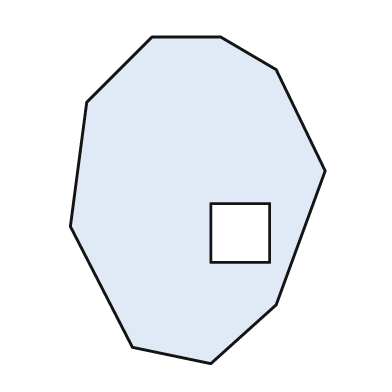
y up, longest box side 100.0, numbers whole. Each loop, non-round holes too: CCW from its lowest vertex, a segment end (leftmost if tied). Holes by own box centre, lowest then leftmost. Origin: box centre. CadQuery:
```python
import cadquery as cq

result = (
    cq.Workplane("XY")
    .moveTo(4.0, -50.0)
    .lineTo(24.0, -32.0)
    .lineTo(39.0, 9.0)
    .lineTo(24.0, 40.0)
    .lineTo(7.0, 50.0)
    .lineTo(-14.0, 50.0)
    .lineTo(-34.0, 30.0)
    .lineTo(-39.0, -8.0)
    .lineTo(-20.0, -45.0)
    .close()
    .moveTo(4.0, -19.0)
    .lineTo(22.0, -19.0)
    .lineTo(22.0, -1.0)
    .lineTo(4.0, -1.0)
    .close()
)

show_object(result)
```